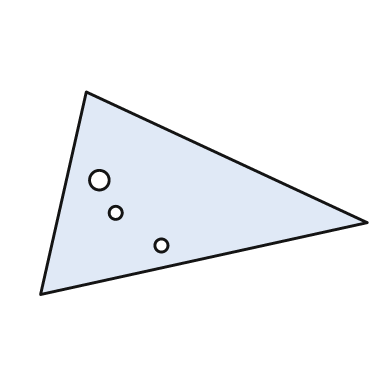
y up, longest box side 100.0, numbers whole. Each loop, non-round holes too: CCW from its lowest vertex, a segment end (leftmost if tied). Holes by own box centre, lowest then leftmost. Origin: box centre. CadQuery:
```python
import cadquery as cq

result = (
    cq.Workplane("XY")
    .moveTo(-50.0, -31.0)
    .lineTo(50.0, -9.0)
    .lineTo(-36.0, 31.0)
    .close()
    .moveTo(-13.0, -16.0)
    .circle(2.0)
    .moveTo(-27.0, -6.0)
    .circle(2.0)
    .moveTo(-32.0, 4.0)
    .circle(3.0)
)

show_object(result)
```